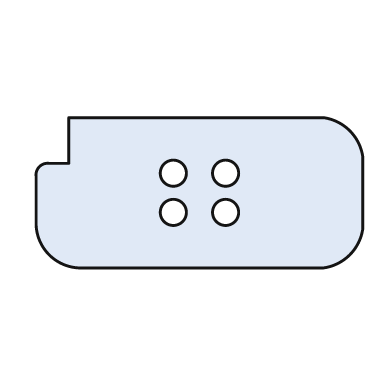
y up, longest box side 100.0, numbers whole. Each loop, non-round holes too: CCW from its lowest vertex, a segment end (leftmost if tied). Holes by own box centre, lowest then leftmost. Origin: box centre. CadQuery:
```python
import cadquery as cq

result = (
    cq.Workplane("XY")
    .moveTo(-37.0, -23.0)
    .lineTo(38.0, -23.0)
    .threePointArc((46.0, -19.0), (50.0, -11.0))
    .lineTo(50.0, 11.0)
    .threePointArc((46.0, 19.0), (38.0, 23.0))
    .lineTo(-40.0, 23.0)
    .lineTo(-40.0, 9.0)
    .lineTo(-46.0, 9.0)
    .threePointArc((-49.0, 8.0), (-50.0, 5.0))
    .lineTo(-50.0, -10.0)
    .threePointArc((-46.0, -19.0), (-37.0, -23.0))
    .close()
    .moveTo(-8.0, -6.0)
    .circle(4.0)
    .moveTo(8.0, -6.0)
    .circle(4.0)
    .moveTo(-8.0, 6.0)
    .circle(4.0)
    .moveTo(8.0, 6.0)
    .circle(4.0)
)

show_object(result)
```